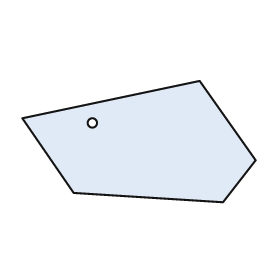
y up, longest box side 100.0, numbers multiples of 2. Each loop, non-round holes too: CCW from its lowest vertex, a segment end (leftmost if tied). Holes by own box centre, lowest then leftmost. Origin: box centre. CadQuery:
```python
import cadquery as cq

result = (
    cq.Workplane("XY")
    .moveTo(36.0, -26.0)
    .lineTo(50.0, -8.0)
    .lineTo(26.0, 26.0)
    .lineTo(-50.0, 10.0)
    .lineTo(-28.0, -22.0)
    .close()
    .moveTo(-20.0, 8.0)
    .circle(2.0)
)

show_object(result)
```